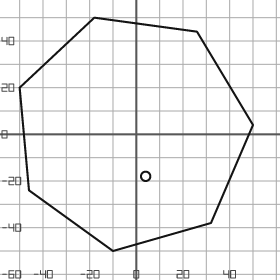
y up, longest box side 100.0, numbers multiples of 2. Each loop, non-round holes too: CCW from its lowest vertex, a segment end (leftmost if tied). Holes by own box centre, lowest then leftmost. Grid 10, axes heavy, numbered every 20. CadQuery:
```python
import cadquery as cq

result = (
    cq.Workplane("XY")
    .moveTo(-10.0, -50.0)
    .lineTo(32.0, -38.0)
    .lineTo(50.0, 4.0)
    .lineTo(26.0, 44.0)
    .lineTo(-18.0, 50.0)
    .lineTo(-50.0, 20.0)
    .lineTo(-46.0, -24.0)
    .close()
    .moveTo(4.0, -18.0)
    .circle(2.0)
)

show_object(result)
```